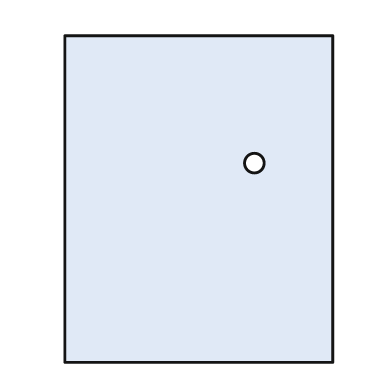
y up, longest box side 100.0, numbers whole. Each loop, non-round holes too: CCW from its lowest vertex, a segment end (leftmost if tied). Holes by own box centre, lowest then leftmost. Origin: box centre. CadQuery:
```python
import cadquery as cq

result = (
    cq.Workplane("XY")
    .moveTo(-41.0, -50.0)
    .lineTo(41.0, -50.0)
    .lineTo(41.0, 50.0)
    .lineTo(-41.0, 50.0)
    .close()
    .moveTo(17.0, 11.0)
    .circle(3.0)
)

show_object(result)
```